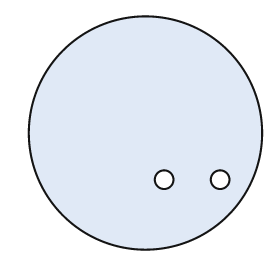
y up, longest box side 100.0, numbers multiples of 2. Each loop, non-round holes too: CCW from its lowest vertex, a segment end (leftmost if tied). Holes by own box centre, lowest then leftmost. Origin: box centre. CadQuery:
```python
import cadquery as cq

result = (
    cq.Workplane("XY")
    .moveTo(0.0, 0.0)
    .circle(50.0)
    .moveTo(8.0, -20.0)
    .circle(4.0)
    .moveTo(32.0, -20.0)
    .circle(4.0)
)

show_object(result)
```